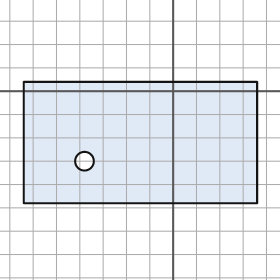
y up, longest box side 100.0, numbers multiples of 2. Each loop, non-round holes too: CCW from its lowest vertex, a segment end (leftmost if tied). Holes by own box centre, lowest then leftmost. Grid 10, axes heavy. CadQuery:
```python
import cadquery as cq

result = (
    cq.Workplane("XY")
    .moveTo(-64.0, -48.0)
    .lineTo(36.0, -48.0)
    .lineTo(36.0, 4.0)
    .lineTo(-64.0, 4.0)
    .close()
    .moveTo(-38.0, -30.0)
    .circle(4.0)
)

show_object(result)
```